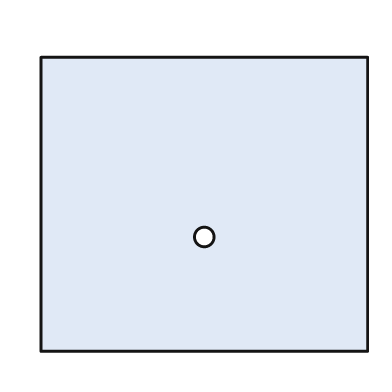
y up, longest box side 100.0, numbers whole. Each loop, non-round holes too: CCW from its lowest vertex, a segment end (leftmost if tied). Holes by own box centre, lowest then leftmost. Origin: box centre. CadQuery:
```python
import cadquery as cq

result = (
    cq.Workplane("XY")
    .moveTo(-50.0, -45.0)
    .lineTo(50.0, -45.0)
    .lineTo(50.0, 45.0)
    .lineTo(-50.0, 45.0)
    .close()
    .moveTo(0.0, -10.0)
    .circle(3.0)
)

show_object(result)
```